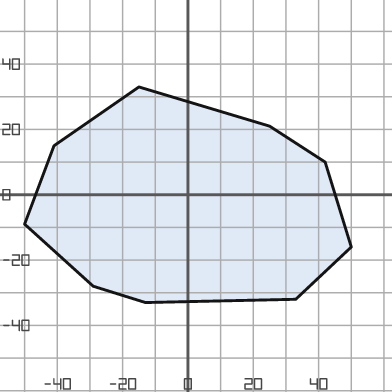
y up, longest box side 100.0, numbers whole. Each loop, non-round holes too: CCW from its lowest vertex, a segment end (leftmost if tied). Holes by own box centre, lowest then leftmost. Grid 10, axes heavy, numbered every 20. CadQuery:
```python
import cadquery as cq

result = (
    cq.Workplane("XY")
    .moveTo(-13.0, -33.0)
    .lineTo(33.0, -32.0)
    .lineTo(50.0, -16.0)
    .lineTo(42.0, 10.0)
    .lineTo(25.0, 21.0)
    .lineTo(-15.0, 33.0)
    .lineTo(-41.0, 15.0)
    .lineTo(-50.0, -9.0)
    .lineTo(-29.0, -28.0)
    .close()
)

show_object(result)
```